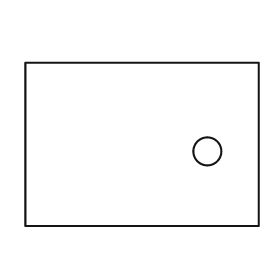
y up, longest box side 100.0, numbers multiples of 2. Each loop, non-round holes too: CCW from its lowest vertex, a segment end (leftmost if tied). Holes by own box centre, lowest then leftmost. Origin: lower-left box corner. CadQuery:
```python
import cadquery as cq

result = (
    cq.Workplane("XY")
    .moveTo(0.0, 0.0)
    .lineTo(100.0, 0.0)
    .lineTo(100.0, 70.0)
    .lineTo(0.0, 70.0)
    .close()
    .moveTo(78.0, 32.0)
    .circle(6.0)
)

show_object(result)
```